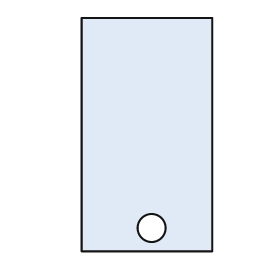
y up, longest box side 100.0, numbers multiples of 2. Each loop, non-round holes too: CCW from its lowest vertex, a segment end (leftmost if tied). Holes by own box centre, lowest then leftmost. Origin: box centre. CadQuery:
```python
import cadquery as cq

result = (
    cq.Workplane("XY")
    .moveTo(-28.0, -50.0)
    .lineTo(28.0, -50.0)
    .lineTo(28.0, 50.0)
    .lineTo(-28.0, 50.0)
    .close()
    .moveTo(2.0, -40.0)
    .circle(6.0)
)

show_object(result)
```